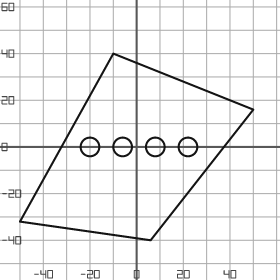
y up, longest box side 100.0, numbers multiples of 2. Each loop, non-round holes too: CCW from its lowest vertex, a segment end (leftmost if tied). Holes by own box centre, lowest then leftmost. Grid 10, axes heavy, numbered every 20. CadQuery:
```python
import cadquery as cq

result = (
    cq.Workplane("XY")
    .moveTo(6.0, -40.0)
    .lineTo(50.0, 16.0)
    .lineTo(-10.0, 40.0)
    .lineTo(-50.0, -32.0)
    .close()
    .moveTo(-20.0, 0.0)
    .circle(4.0)
    .moveTo(-6.0, 0.0)
    .circle(4.0)
    .moveTo(8.0, 0.0)
    .circle(4.0)
    .moveTo(22.0, 0.0)
    .circle(4.0)
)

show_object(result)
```